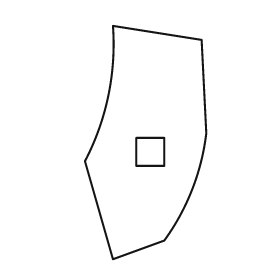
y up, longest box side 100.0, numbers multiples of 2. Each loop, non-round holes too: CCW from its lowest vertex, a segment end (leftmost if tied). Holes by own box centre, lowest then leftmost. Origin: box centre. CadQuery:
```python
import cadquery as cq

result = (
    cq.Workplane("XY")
    .moveTo(-14.0, -50.0)
    .lineTo(8.0, -42.0)
    .threePointArc((20.0, -20.0), (26.0, 4.0))
    .lineTo(24.0, 44.0)
    .lineTo(-14.0, 50.0)
    .threePointArc((-16.0, 20.0), (-26.0, -8.0))
    .close()
    .moveTo(-4.0, -10.0)
    .lineTo(8.0, -10.0)
    .lineTo(8.0, 2.0)
    .lineTo(-4.0, 2.0)
    .close()
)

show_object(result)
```